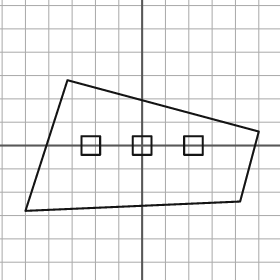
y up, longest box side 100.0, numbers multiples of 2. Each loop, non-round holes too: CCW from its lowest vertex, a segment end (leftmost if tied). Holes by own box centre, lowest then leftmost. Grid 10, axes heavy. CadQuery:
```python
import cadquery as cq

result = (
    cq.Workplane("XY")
    .moveTo(-50.0, -28.0)
    .lineTo(42.0, -24.0)
    .lineTo(50.0, 6.0)
    .lineTo(-32.0, 28.0)
    .close()
    .moveTo(-26.0, -4.0)
    .lineTo(-18.0, -4.0)
    .lineTo(-18.0, 4.0)
    .lineTo(-26.0, 4.0)
    .close()
    .moveTo(-4.0, -4.0)
    .lineTo(4.0, -4.0)
    .lineTo(4.0, 4.0)
    .lineTo(-4.0, 4.0)
    .close()
    .moveTo(18.0, -4.0)
    .lineTo(26.0, -4.0)
    .lineTo(26.0, 4.0)
    .lineTo(18.0, 4.0)
    .close()
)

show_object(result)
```